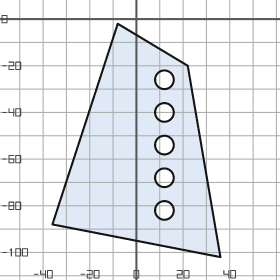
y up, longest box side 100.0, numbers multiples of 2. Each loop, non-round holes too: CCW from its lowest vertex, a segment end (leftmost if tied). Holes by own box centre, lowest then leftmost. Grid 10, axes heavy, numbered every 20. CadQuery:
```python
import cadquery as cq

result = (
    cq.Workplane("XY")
    .moveTo(36.0, -102.0)
    .lineTo(22.0, -20.0)
    .lineTo(-8.0, -2.0)
    .lineTo(-36.0, -88.0)
    .close()
    .moveTo(12.0, -82.0)
    .circle(4.0)
    .moveTo(12.0, -68.0)
    .circle(4.0)
    .moveTo(12.0, -54.0)
    .circle(4.0)
    .moveTo(12.0, -40.0)
    .circle(4.0)
    .moveTo(12.0, -26.0)
    .circle(4.0)
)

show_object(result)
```